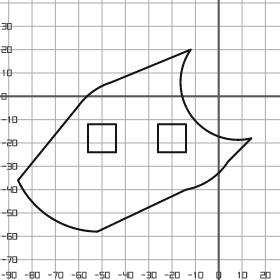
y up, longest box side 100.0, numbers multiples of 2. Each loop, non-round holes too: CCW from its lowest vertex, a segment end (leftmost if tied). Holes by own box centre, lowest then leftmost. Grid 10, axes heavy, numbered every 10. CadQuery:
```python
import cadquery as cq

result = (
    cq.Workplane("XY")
    .moveTo(-52.0, -58.0)
    .lineTo(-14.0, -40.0)
    .threePointArc((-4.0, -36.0), (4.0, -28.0))
    .lineTo(14.0, -18.0)
    .threePointArc((-12.0, -8.0), (-12.0, 20.0))
    .lineTo(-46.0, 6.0)
    .threePointArc((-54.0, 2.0), (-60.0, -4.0))
    .lineTo(-86.0, -36.0)
    .threePointArc((-72.0, -52.0), (-52.0, -58.0))
    .close()
    .moveTo(-56.0, -24.0)
    .lineTo(-44.0, -24.0)
    .lineTo(-44.0, -12.0)
    .lineTo(-56.0, -12.0)
    .close()
    .moveTo(-26.0, -24.0)
    .lineTo(-14.0, -24.0)
    .lineTo(-14.0, -12.0)
    .lineTo(-26.0, -12.0)
    .close()
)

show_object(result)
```